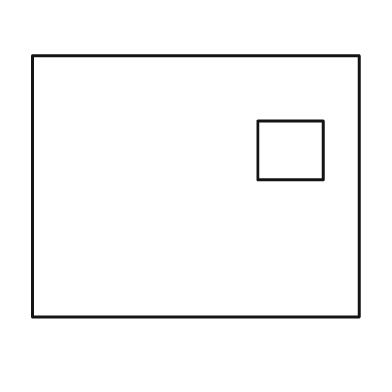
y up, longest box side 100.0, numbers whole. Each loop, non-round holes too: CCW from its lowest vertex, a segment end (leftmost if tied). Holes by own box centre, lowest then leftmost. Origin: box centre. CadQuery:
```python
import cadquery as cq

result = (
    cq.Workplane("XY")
    .moveTo(-50.0, -40.0)
    .lineTo(50.0, -40.0)
    .lineTo(50.0, 40.0)
    .lineTo(-50.0, 40.0)
    .close()
    .moveTo(19.0, 2.0)
    .lineTo(39.0, 2.0)
    .lineTo(39.0, 20.0)
    .lineTo(19.0, 20.0)
    .close()
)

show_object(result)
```